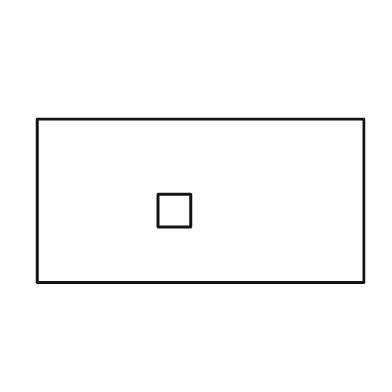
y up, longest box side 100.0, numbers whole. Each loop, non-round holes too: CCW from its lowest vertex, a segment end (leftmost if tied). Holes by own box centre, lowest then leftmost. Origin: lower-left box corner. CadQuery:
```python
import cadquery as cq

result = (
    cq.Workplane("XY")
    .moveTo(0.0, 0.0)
    .lineTo(100.0, 0.0)
    .lineTo(100.0, 50.0)
    .lineTo(0.0, 50.0)
    .close()
    .moveTo(37.0, 17.0)
    .lineTo(47.0, 17.0)
    .lineTo(47.0, 27.0)
    .lineTo(37.0, 27.0)
    .close()
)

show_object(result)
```